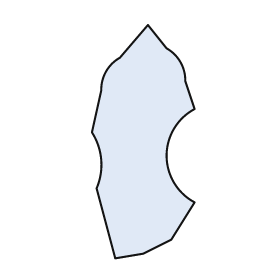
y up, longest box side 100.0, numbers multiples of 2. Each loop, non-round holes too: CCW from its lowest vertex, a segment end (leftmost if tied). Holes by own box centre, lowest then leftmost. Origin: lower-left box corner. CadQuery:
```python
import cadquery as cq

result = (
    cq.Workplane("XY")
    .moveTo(10.0, 0.0)
    .lineTo(22.0, 2.0)
    .lineTo(34.0, 8.0)
    .lineTo(44.0, 24.0)
    .threePointArc((32.0, 44.0), (44.0, 64.0))
    .lineTo(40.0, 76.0)
    .threePointArc((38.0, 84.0), (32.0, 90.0))
    .lineTo(24.0, 100.0)
    .lineTo(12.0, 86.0)
    .threePointArc((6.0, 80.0), (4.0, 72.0))
    .lineTo(0.0, 54.0)
    .threePointArc((4.0, 42.0), (2.0, 30.0))
    .close()
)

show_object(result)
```